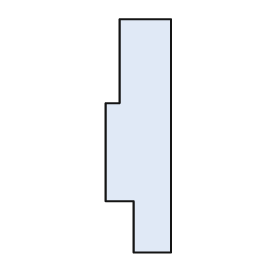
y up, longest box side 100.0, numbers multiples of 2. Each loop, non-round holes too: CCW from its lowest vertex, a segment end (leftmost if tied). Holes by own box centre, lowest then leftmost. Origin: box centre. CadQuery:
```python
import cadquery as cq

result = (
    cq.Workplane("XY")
    .moveTo(-2.0, -50.0)
    .lineTo(14.0, -50.0)
    .lineTo(14.0, 50.0)
    .lineTo(-8.0, 50.0)
    .lineTo(-8.0, 14.0)
    .lineTo(-14.0, 14.0)
    .lineTo(-14.0, -28.0)
    .lineTo(-2.0, -28.0)
    .close()
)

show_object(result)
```